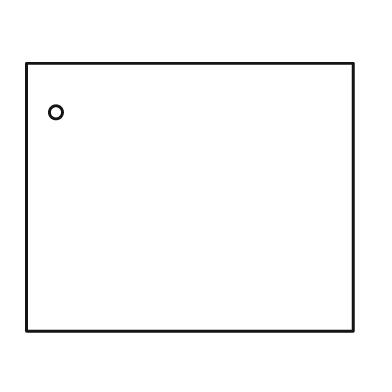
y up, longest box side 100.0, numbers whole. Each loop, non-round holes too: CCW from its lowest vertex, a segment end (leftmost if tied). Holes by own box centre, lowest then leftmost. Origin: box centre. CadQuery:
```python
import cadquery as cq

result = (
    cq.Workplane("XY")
    .moveTo(-50.0, -41.0)
    .lineTo(50.0, -41.0)
    .lineTo(50.0, 41.0)
    .lineTo(-50.0, 41.0)
    .close()
    .moveTo(-41.0, 26.0)
    .circle(2.0)
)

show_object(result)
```